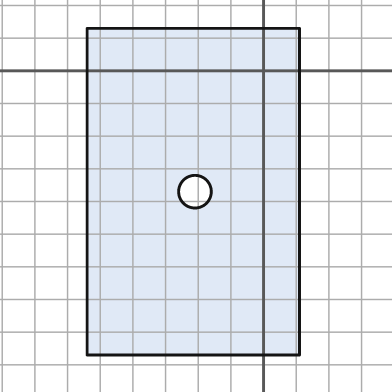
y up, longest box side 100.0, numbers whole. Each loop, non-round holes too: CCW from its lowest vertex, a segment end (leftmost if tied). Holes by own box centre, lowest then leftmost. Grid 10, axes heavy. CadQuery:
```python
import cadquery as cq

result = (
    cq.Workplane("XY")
    .moveTo(-54.0, -87.0)
    .lineTo(11.0, -87.0)
    .lineTo(11.0, 13.0)
    .lineTo(-54.0, 13.0)
    .close()
    .moveTo(-21.0, -37.0)
    .circle(5.0)
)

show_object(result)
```